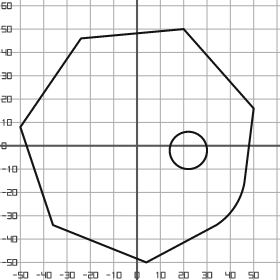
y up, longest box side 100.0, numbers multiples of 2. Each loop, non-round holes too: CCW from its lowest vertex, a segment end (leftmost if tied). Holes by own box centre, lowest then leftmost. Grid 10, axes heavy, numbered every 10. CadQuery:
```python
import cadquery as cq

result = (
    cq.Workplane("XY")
    .moveTo(4.0, -50.0)
    .lineTo(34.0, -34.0)
    .threePointArc((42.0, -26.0), (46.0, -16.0))
    .lineTo(50.0, 16.0)
    .lineTo(20.0, 50.0)
    .lineTo(-24.0, 46.0)
    .lineTo(-50.0, 8.0)
    .lineTo(-36.0, -34.0)
    .close()
    .moveTo(22.0, -2.0)
    .circle(8.0)
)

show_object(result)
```